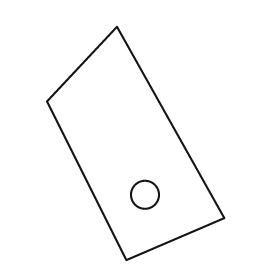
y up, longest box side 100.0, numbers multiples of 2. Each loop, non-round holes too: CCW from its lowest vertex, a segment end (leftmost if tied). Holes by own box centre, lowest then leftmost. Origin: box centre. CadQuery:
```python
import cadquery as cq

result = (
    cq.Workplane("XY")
    .moveTo(-4.0, -50.0)
    .lineTo(38.0, -32.0)
    .lineTo(-8.0, 50.0)
    .lineTo(-38.0, 18.0)
    .close()
    .moveTo(4.0, -22.0)
    .circle(6.0)
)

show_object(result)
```